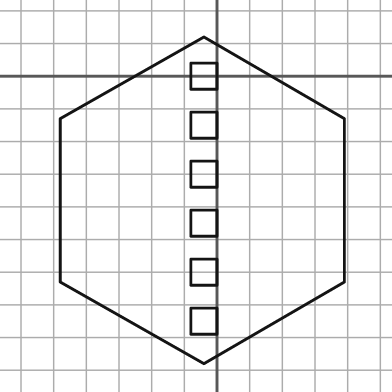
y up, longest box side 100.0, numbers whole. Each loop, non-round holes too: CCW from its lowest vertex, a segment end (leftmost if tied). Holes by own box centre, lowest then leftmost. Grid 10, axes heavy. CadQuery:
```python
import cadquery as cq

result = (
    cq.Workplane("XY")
    .moveTo(-4.0, -88.0)
    .lineTo(39.0, -63.0)
    .lineTo(39.0, -13.0)
    .lineTo(-4.0, 12.0)
    .lineTo(-48.0, -13.0)
    .lineTo(-48.0, -63.0)
    .close()
    .moveTo(-8.0, -79.0)
    .lineTo(0.0, -79.0)
    .lineTo(0.0, -71.0)
    .lineTo(-8.0, -71.0)
    .close()
    .moveTo(-8.0, -64.0)
    .lineTo(0.0, -64.0)
    .lineTo(0.0, -56.0)
    .lineTo(-8.0, -56.0)
    .close()
    .moveTo(-8.0, -49.0)
    .lineTo(0.0, -49.0)
    .lineTo(0.0, -41.0)
    .lineTo(-8.0, -41.0)
    .close()
    .moveTo(-8.0, -34.0)
    .lineTo(0.0, -34.0)
    .lineTo(0.0, -26.0)
    .lineTo(-8.0, -26.0)
    .close()
    .moveTo(-8.0, -19.0)
    .lineTo(0.0, -19.0)
    .lineTo(0.0, -11.0)
    .lineTo(-8.0, -11.0)
    .close()
    .moveTo(-8.0, -4.0)
    .lineTo(0.0, -4.0)
    .lineTo(0.0, 4.0)
    .lineTo(-8.0, 4.0)
    .close()
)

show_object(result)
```